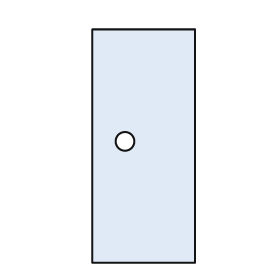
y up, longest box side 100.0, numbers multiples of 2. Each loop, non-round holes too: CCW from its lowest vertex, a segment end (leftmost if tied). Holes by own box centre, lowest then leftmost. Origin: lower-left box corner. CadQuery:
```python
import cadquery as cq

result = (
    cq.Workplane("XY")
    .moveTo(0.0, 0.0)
    .lineTo(44.0, 0.0)
    .lineTo(44.0, 100.0)
    .lineTo(0.0, 100.0)
    .close()
    .moveTo(14.0, 52.0)
    .circle(4.0)
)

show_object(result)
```